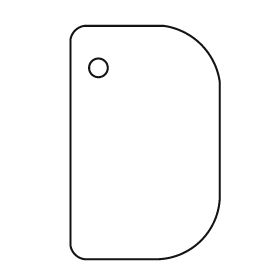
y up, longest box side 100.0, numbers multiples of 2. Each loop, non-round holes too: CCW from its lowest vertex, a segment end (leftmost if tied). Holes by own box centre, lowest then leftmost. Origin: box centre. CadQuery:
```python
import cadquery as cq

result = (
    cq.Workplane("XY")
    .moveTo(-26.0, -50.0)
    .lineTo(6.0, -50.0)
    .threePointArc((24.0, -42.0), (32.0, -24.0))
    .lineTo(32.0, 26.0)
    .threePointArc((24.0, 42.0), (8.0, 50.0))
    .lineTo(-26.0, 50.0)
    .threePointArc((-30.0, 48.0), (-32.0, 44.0))
    .lineTo(-32.0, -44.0)
    .threePointArc((-30.0, -48.0), (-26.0, -50.0))
    .close()
    .moveTo(-20.0, 32.0)
    .circle(4.0)
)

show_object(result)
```